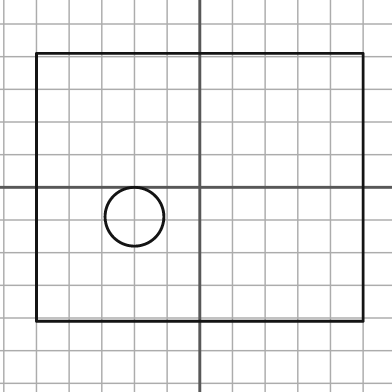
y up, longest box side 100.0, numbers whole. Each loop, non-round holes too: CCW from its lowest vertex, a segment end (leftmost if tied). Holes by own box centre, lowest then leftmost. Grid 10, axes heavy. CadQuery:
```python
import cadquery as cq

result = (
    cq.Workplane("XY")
    .moveTo(-50.0, -41.0)
    .lineTo(50.0, -41.0)
    .lineTo(50.0, 41.0)
    .lineTo(-50.0, 41.0)
    .close()
    .moveTo(-20.0, -9.0)
    .circle(9.0)
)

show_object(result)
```